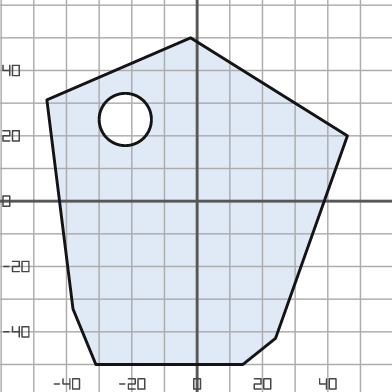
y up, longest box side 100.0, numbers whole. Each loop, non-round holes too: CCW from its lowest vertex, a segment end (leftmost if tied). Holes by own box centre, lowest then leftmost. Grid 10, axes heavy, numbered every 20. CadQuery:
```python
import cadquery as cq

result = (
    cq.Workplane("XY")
    .moveTo(-31.0, -50.0)
    .lineTo(14.0, -50.0)
    .lineTo(24.0, -42.0)
    .lineTo(46.0, 20.0)
    .lineTo(-2.0, 50.0)
    .lineTo(-46.0, 31.0)
    .lineTo(-38.0, -33.0)
    .close()
    .moveTo(-22.0, 25.0)
    .circle(8.0)
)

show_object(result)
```